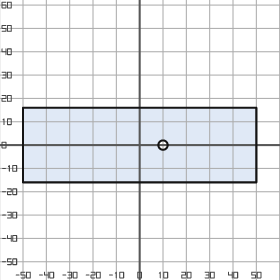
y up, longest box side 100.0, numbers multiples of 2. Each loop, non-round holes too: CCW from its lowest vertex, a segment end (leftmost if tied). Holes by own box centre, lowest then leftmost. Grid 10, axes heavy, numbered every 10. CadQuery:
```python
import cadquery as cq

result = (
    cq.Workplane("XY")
    .moveTo(-50.0, -16.0)
    .lineTo(50.0, -16.0)
    .lineTo(50.0, 16.0)
    .lineTo(-50.0, 16.0)
    .close()
    .moveTo(10.0, 0.0)
    .circle(2.0)
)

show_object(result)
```